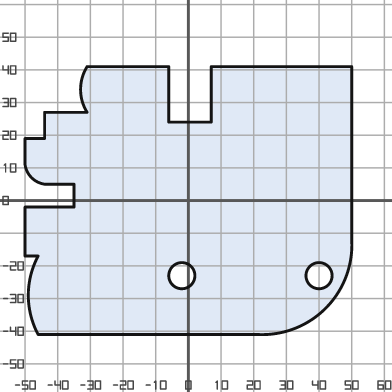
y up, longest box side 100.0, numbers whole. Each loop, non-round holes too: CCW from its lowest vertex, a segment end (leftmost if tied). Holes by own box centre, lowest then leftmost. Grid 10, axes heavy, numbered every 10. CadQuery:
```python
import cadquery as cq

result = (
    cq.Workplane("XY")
    .moveTo(-46.0, -41.0)
    .lineTo(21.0, -41.0)
    .threePointArc((42.0, -33.0), (50.0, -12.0))
    .lineTo(50.0, 41.0)
    .lineTo(7.0, 41.0)
    .lineTo(7.0, 24.0)
    .lineTo(-6.0, 24.0)
    .lineTo(-6.0, 41.0)
    .lineTo(-31.0, 41.0)
    .threePointArc((-33.0, 34.0), (-31.0, 27.0))
    .lineTo(-44.0, 27.0)
    .lineTo(-44.0, 19.0)
    .lineTo(-50.0, 19.0)
    .lineTo(-50.0, 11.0)
    .threePointArc((-48.0, 7.0), (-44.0, 5.0))
    .lineTo(-35.0, 5.0)
    .lineTo(-35.0, -2.0)
    .lineTo(-50.0, -2.0)
    .lineTo(-50.0, -17.0)
    .lineTo(-46.0, -17.0)
    .threePointArc((-49.0, -29.0), (-46.0, -41.0))
    .close()
    .moveTo(-2.0, -23.0)
    .circle(4.0)
    .moveTo(40.0, -23.0)
    .circle(4.0)
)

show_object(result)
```